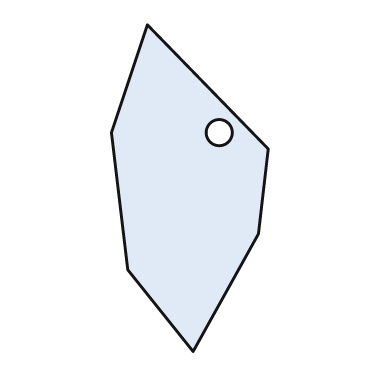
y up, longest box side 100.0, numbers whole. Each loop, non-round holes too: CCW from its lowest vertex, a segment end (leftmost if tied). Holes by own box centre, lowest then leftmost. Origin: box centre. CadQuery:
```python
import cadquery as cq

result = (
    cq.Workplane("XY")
    .moveTo(1.0, -50.0)
    .lineTo(21.0, -14.0)
    .lineTo(24.0, 12.0)
    .lineTo(-13.0, 50.0)
    .lineTo(-24.0, 17.0)
    .lineTo(-19.0, -25.0)
    .close()
    .moveTo(9.0, 17.0)
    .circle(4.0)
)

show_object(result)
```